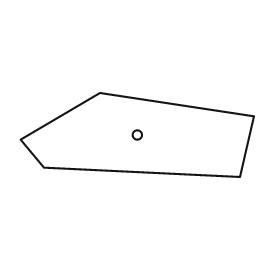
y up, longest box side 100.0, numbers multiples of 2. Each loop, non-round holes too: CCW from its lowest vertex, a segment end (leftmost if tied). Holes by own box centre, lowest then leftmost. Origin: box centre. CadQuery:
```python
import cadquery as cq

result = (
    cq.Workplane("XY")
    .moveTo(44.0, -18.0)
    .lineTo(50.0, 8.0)
    .lineTo(-16.0, 18.0)
    .lineTo(-50.0, -2.0)
    .lineTo(-40.0, -14.0)
    .close()
    .moveTo(0.0, 0.0)
    .circle(2.0)
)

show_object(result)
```